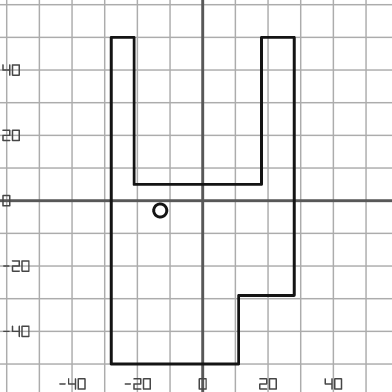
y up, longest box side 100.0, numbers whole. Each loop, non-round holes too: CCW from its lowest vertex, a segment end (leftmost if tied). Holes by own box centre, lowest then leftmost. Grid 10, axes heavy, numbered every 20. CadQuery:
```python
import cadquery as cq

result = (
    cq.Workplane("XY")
    .moveTo(-28.0, -50.0)
    .lineTo(11.0, -50.0)
    .lineTo(11.0, -29.0)
    .lineTo(28.0, -29.0)
    .lineTo(28.0, 50.0)
    .lineTo(18.0, 50.0)
    .lineTo(18.0, 5.0)
    .lineTo(-21.0, 5.0)
    .lineTo(-21.0, 50.0)
    .lineTo(-28.0, 50.0)
    .close()
    .moveTo(-13.0, -3.0)
    .circle(2.0)
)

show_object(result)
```